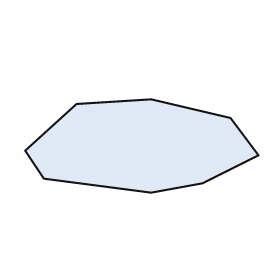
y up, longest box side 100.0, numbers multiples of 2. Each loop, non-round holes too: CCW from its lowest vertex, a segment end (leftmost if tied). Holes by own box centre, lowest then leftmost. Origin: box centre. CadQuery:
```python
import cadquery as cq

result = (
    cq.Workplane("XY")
    .moveTo(4.0, -20.0)
    .lineTo(26.0, -16.0)
    .lineTo(50.0, -4.0)
    .lineTo(38.0, 12.0)
    .lineTo(4.0, 20.0)
    .lineTo(-28.0, 18.0)
    .lineTo(-50.0, -2.0)
    .lineTo(-42.0, -14.0)
    .close()
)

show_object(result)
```